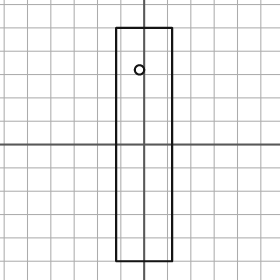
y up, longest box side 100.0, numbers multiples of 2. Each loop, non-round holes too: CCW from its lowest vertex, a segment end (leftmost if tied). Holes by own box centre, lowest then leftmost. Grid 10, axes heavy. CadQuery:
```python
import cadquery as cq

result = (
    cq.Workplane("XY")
    .moveTo(-12.0, -50.0)
    .lineTo(12.0, -50.0)
    .lineTo(12.0, 50.0)
    .lineTo(-12.0, 50.0)
    .close()
    .moveTo(-2.0, 32.0)
    .circle(2.0)
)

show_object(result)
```